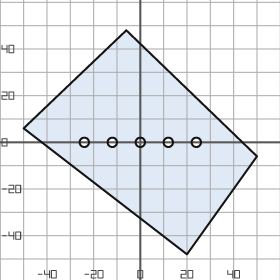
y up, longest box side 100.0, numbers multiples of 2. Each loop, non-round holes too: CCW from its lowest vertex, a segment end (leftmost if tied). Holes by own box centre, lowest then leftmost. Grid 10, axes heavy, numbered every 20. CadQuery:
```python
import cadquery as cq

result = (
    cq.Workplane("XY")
    .moveTo(20.0, -48.0)
    .lineTo(50.0, -6.0)
    .lineTo(-6.0, 48.0)
    .lineTo(-50.0, 6.0)
    .close()
    .moveTo(-24.0, 0.0)
    .circle(2.0)
    .moveTo(-12.0, 0.0)
    .circle(2.0)
    .moveTo(0.0, 0.0)
    .circle(2.0)
    .moveTo(12.0, 0.0)
    .circle(2.0)
    .moveTo(24.0, 0.0)
    .circle(2.0)
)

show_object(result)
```